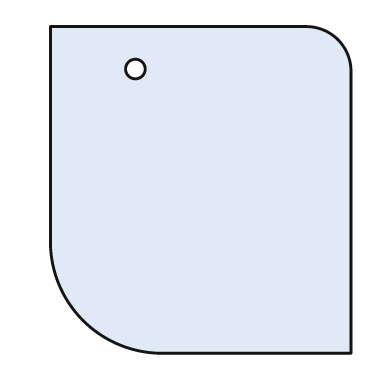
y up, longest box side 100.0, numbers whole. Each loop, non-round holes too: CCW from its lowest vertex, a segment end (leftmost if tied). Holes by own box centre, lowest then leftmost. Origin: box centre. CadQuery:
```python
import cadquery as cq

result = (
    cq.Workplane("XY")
    .moveTo(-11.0, -50.0)
    .lineTo(46.0, -50.0)
    .lineTo(46.0, 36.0)
    .threePointArc((42.0, 46.0), (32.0, 50.0))
    .lineTo(-46.0, 50.0)
    .lineTo(-46.0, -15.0)
    .threePointArc((-36.0, -40.0), (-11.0, -50.0))
    .close()
    .moveTo(-20.0, 37.0)
    .circle(3.0)
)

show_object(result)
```